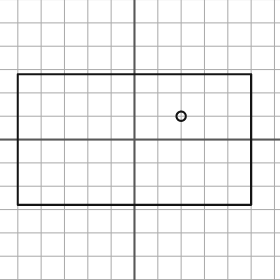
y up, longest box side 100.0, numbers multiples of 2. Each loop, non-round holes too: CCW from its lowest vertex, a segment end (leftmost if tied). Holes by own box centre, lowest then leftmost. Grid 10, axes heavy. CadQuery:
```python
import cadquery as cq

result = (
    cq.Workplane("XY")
    .moveTo(-50.0, -28.0)
    .lineTo(50.0, -28.0)
    .lineTo(50.0, 28.0)
    .lineTo(-50.0, 28.0)
    .close()
    .moveTo(20.0, 10.0)
    .circle(2.0)
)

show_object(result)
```